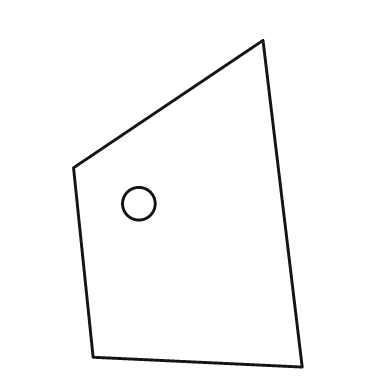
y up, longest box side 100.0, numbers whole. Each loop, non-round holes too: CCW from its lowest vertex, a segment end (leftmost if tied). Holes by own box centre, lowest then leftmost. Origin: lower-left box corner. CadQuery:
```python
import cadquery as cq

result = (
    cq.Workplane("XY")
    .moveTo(70.0, 0.0)
    .lineTo(58.0, 100.0)
    .lineTo(0.0, 61.0)
    .lineTo(6.0, 3.0)
    .close()
    .moveTo(20.0, 50.0)
    .circle(5.0)
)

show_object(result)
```